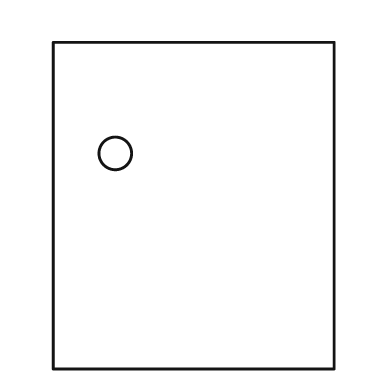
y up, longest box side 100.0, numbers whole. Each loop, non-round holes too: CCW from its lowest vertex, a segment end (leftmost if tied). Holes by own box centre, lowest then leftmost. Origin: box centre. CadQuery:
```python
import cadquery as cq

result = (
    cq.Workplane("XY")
    .moveTo(-43.0, -50.0)
    .lineTo(43.0, -50.0)
    .lineTo(43.0, 50.0)
    .lineTo(-43.0, 50.0)
    .close()
    .moveTo(-24.0, 16.0)
    .circle(5.0)
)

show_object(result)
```